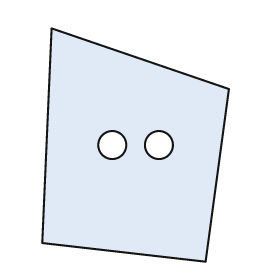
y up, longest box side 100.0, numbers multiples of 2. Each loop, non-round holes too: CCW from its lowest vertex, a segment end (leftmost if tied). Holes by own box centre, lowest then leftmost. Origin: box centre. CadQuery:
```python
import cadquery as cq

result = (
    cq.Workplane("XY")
    .moveTo(30.0, -50.0)
    .lineTo(40.0, 24.0)
    .lineTo(-36.0, 50.0)
    .lineTo(-40.0, -42.0)
    .close()
    .moveTo(-10.0, 0.0)
    .circle(6.0)
    .moveTo(10.0, 0.0)
    .circle(6.0)
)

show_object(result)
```